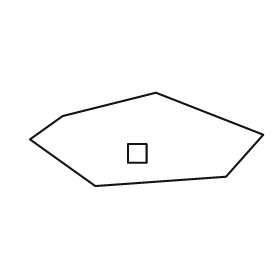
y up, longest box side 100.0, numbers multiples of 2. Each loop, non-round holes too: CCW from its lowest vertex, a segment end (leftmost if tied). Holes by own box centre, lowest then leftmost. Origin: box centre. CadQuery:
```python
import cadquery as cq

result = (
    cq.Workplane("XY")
    .moveTo(-22.0, -20.0)
    .lineTo(34.0, -16.0)
    .lineTo(50.0, 2.0)
    .lineTo(4.0, 20.0)
    .lineTo(-36.0, 10.0)
    .lineTo(-50.0, 0.0)
    .close()
    .moveTo(-8.0, -10.0)
    .lineTo(0.0, -10.0)
    .lineTo(0.0, -2.0)
    .lineTo(-8.0, -2.0)
    .close()
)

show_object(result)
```